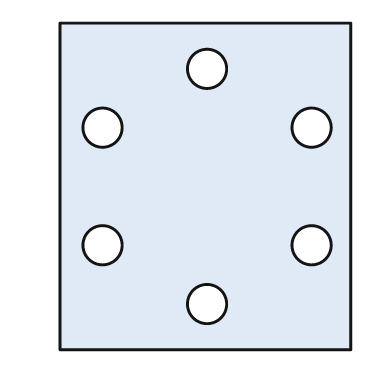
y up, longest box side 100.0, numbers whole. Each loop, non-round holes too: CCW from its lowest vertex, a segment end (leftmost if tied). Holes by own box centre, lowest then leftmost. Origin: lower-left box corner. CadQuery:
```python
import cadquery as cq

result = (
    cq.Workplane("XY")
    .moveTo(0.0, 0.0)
    .lineTo(89.0, 0.0)
    .lineTo(89.0, 100.0)
    .lineTo(0.0, 100.0)
    .close()
    .moveTo(45.0, 14.0)
    .circle(6.0)
    .moveTo(13.0, 32.0)
    .circle(6.0)
    .moveTo(77.0, 32.0)
    .circle(6.0)
    .moveTo(13.0, 68.0)
    .circle(6.0)
    .moveTo(77.0, 68.0)
    .circle(6.0)
    .moveTo(45.0, 86.0)
    .circle(6.0)
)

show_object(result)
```